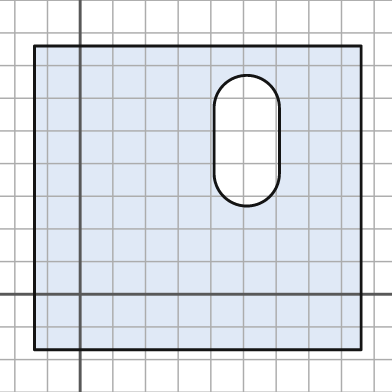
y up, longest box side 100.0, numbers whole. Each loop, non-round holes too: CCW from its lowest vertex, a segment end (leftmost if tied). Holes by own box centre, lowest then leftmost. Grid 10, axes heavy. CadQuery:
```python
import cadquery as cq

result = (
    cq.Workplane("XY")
    .moveTo(-14.0, -17.0)
    .lineTo(86.0, -17.0)
    .lineTo(86.0, 76.0)
    .lineTo(-14.0, 76.0)
    .close()
    .moveTo(41.0, 37.0)
    .threePointArc((51.0, 27.0), (61.0, 37.0))
    .lineTo(61.0, 57.0)
    .threePointArc((51.0, 67.0), (41.0, 57.0))
    .close()
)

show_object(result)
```